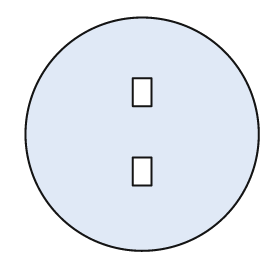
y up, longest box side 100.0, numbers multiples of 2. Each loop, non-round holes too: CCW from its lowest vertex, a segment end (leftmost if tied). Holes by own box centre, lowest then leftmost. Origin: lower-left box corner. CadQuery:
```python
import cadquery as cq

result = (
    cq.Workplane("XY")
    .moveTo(50.0, 50.0)
    .circle(50.0)
    .moveTo(46.0, 28.0)
    .lineTo(54.0, 28.0)
    .lineTo(54.0, 40.0)
    .lineTo(46.0, 40.0)
    .close()
    .moveTo(46.0, 62.0)
    .lineTo(54.0, 62.0)
    .lineTo(54.0, 74.0)
    .lineTo(46.0, 74.0)
    .close()
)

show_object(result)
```